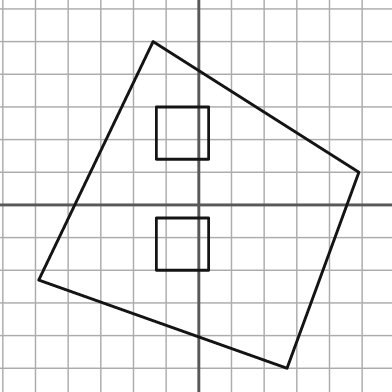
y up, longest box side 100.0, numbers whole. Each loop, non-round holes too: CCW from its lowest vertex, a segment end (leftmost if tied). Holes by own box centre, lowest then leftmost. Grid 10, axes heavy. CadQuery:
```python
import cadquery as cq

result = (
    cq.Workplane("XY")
    .moveTo(27.0, -50.0)
    .lineTo(49.0, 10.0)
    .lineTo(-14.0, 50.0)
    .lineTo(-49.0, -23.0)
    .close()
    .moveTo(-13.0, -20.0)
    .lineTo(3.0, -20.0)
    .lineTo(3.0, -4.0)
    .lineTo(-13.0, -4.0)
    .close()
    .moveTo(-13.0, 14.0)
    .lineTo(3.0, 14.0)
    .lineTo(3.0, 30.0)
    .lineTo(-13.0, 30.0)
    .close()
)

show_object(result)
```